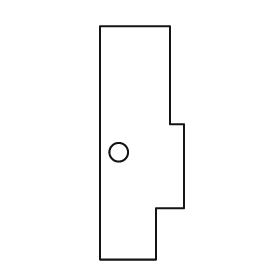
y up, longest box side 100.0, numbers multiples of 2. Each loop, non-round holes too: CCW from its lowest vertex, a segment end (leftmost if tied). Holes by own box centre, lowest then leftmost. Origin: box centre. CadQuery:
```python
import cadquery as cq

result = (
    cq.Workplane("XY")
    .moveTo(-18.0, -50.0)
    .lineTo(6.0, -50.0)
    .lineTo(6.0, -28.0)
    .lineTo(18.0, -28.0)
    .lineTo(18.0, 8.0)
    .lineTo(12.0, 8.0)
    .lineTo(12.0, 50.0)
    .lineTo(-18.0, 50.0)
    .close()
    .moveTo(-10.0, -4.0)
    .circle(4.0)
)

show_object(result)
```